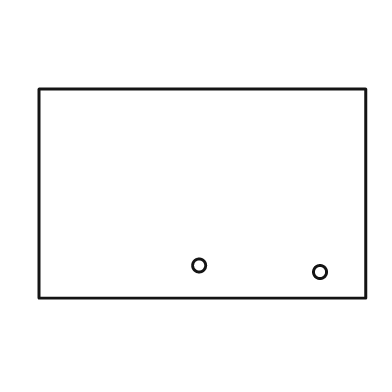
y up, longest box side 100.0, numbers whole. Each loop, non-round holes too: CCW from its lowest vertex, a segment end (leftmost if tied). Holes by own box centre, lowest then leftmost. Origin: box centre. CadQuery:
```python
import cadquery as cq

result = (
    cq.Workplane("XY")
    .moveTo(-50.0, -32.0)
    .lineTo(50.0, -32.0)
    .lineTo(50.0, 32.0)
    .lineTo(-50.0, 32.0)
    .close()
    .moveTo(36.0, -24.0)
    .circle(2.0)
    .moveTo(-1.0, -22.0)
    .circle(2.0)
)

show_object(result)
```